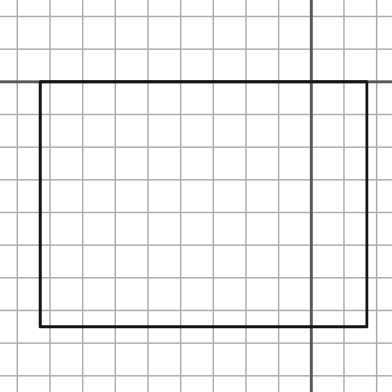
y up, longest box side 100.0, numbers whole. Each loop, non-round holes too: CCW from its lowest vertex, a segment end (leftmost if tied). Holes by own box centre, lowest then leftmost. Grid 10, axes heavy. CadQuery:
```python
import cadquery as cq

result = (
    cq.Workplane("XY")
    .moveTo(-83.0, -75.0)
    .lineTo(17.0, -75.0)
    .lineTo(17.0, 0.0)
    .lineTo(-83.0, 0.0)
    .close()
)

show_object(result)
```